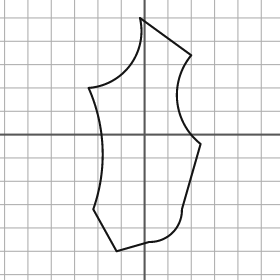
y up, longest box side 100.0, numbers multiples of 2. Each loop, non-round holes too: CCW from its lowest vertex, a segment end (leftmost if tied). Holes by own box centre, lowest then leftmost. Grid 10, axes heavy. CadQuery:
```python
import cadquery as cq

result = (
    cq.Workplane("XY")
    .moveTo(-12.0, -50.0)
    .lineTo(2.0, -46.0)
    .threePointArc((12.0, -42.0), (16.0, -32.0))
    .lineTo(24.0, -4.0)
    .threePointArc((14.0, 14.0), (20.0, 34.0))
    .lineTo(-2.0, 50.0)
    .threePointArc((-6.0, 30.0), (-24.0, 20.0))
    .threePointArc((-18.0, -6.0), (-22.0, -32.0))
    .close()
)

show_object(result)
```